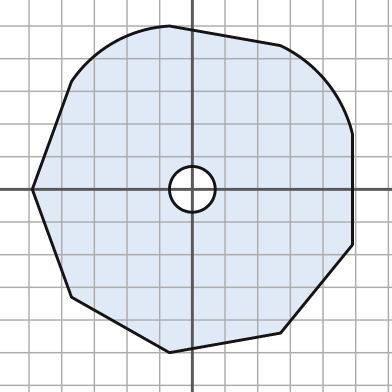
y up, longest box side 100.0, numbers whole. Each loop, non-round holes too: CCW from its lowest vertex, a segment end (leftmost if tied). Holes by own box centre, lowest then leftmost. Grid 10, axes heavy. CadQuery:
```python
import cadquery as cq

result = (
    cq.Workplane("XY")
    .moveTo(-7.0, -50.0)
    .lineTo(27.0, -44.0)
    .lineTo(49.0, -17.0)
    .lineTo(49.0, 17.0)
    .threePointArc((41.0, 33.0), (27.0, 44.0))
    .lineTo(-7.0, 50.0)
    .threePointArc((-24.0, 45.0), (-37.0, 33.0))
    .lineTo(-49.0, 0.0)
    .lineTo(-37.0, -33.0)
    .close()
    .moveTo(0.0, 0.0)
    .circle(7.0)
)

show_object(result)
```